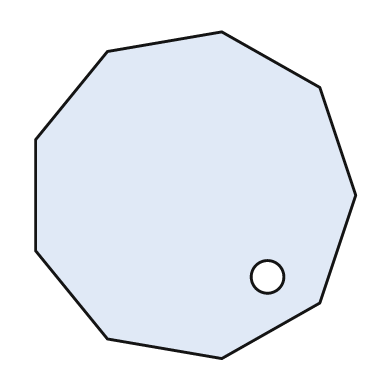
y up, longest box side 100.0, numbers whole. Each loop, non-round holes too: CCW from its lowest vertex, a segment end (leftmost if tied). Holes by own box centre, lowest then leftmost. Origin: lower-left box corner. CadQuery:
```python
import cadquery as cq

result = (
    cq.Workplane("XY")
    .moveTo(57.0, 0.0)
    .lineTo(87.0, 17.0)
    .lineTo(98.0, 50.0)
    .lineTo(87.0, 83.0)
    .lineTo(57.0, 100.0)
    .lineTo(22.0, 94.0)
    .lineTo(0.0, 67.0)
    .lineTo(0.0, 33.0)
    .lineTo(22.0, 6.0)
    .close()
    .moveTo(71.0, 25.0)
    .circle(5.0)
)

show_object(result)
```